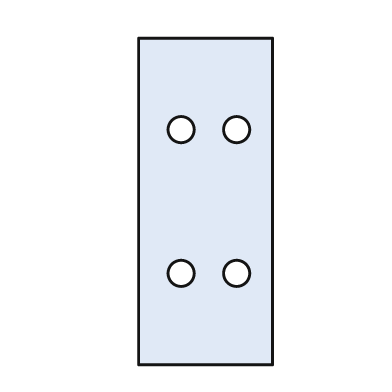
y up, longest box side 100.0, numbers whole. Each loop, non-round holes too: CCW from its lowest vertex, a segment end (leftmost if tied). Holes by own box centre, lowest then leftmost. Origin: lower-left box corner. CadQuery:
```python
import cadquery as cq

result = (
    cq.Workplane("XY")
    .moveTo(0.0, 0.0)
    .lineTo(41.0, 0.0)
    .lineTo(41.0, 100.0)
    .lineTo(0.0, 100.0)
    .close()
    .moveTo(13.0, 28.0)
    .circle(4.0)
    .moveTo(30.0, 28.0)
    .circle(4.0)
    .moveTo(13.0, 72.0)
    .circle(4.0)
    .moveTo(30.0, 72.0)
    .circle(4.0)
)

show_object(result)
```